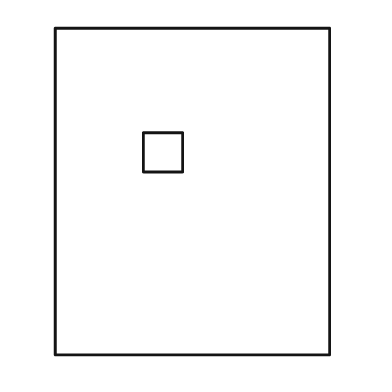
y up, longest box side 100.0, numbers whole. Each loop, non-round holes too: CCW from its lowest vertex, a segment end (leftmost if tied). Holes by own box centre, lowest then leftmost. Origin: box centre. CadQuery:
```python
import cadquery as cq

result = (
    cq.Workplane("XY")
    .moveTo(-42.0, -50.0)
    .lineTo(42.0, -50.0)
    .lineTo(42.0, 50.0)
    .lineTo(-42.0, 50.0)
    .close()
    .moveTo(-15.0, 6.0)
    .lineTo(-3.0, 6.0)
    .lineTo(-3.0, 18.0)
    .lineTo(-15.0, 18.0)
    .close()
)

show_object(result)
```